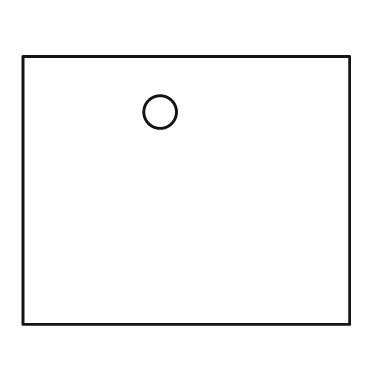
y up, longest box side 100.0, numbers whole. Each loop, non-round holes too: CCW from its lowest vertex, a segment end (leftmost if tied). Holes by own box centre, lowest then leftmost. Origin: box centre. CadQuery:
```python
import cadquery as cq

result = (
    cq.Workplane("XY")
    .moveTo(-50.0, -41.0)
    .lineTo(50.0, -41.0)
    .lineTo(50.0, 41.0)
    .lineTo(-50.0, 41.0)
    .close()
    .moveTo(-8.0, 24.0)
    .circle(5.0)
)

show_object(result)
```